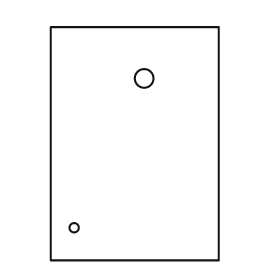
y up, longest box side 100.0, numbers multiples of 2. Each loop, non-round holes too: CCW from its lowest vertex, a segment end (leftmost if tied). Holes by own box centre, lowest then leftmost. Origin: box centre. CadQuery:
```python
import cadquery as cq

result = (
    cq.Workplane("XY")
    .moveTo(-36.0, -50.0)
    .lineTo(36.0, -50.0)
    .lineTo(36.0, 50.0)
    .lineTo(-36.0, 50.0)
    .close()
    .moveTo(-26.0, -36.0)
    .circle(2.0)
    .moveTo(4.0, 28.0)
    .circle(4.0)
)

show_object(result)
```